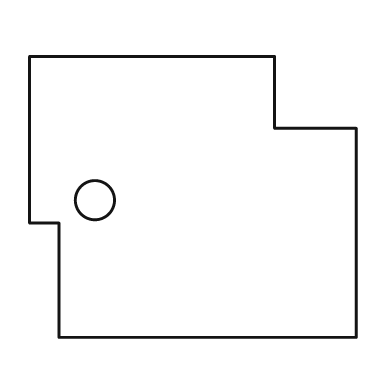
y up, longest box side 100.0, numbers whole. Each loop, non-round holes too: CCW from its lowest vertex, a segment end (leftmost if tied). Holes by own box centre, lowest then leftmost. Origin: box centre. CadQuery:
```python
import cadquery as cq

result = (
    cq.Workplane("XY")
    .moveTo(-41.0, -43.0)
    .lineTo(50.0, -43.0)
    .lineTo(50.0, 21.0)
    .lineTo(25.0, 21.0)
    .lineTo(25.0, 43.0)
    .lineTo(-50.0, 43.0)
    .lineTo(-50.0, -8.0)
    .lineTo(-41.0, -8.0)
    .close()
    .moveTo(-30.0, -1.0)
    .circle(6.0)
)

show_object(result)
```